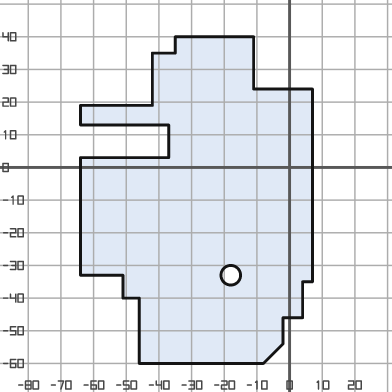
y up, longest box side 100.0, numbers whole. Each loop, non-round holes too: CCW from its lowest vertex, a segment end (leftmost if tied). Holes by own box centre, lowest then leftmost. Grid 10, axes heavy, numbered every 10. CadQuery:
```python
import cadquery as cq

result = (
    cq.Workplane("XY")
    .moveTo(-46.0, -60.0)
    .lineTo(-8.0, -60.0)
    .lineTo(-2.0, -54.0)
    .lineTo(-2.0, -46.0)
    .lineTo(4.0, -46.0)
    .lineTo(4.0, -35.0)
    .lineTo(7.0, -35.0)
    .lineTo(7.0, 24.0)
    .lineTo(-11.0, 24.0)
    .lineTo(-11.0, 40.0)
    .lineTo(-35.0, 40.0)
    .lineTo(-35.0, 35.0)
    .lineTo(-42.0, 35.0)
    .lineTo(-42.0, 19.0)
    .lineTo(-64.0, 19.0)
    .lineTo(-64.0, 13.0)
    .lineTo(-37.0, 13.0)
    .lineTo(-37.0, 3.0)
    .lineTo(-64.0, 3.0)
    .lineTo(-64.0, -33.0)
    .lineTo(-51.0, -33.0)
    .lineTo(-51.0, -40.0)
    .lineTo(-46.0, -40.0)
    .close()
    .moveTo(-18.0, -33.0)
    .circle(3.0)
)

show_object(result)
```